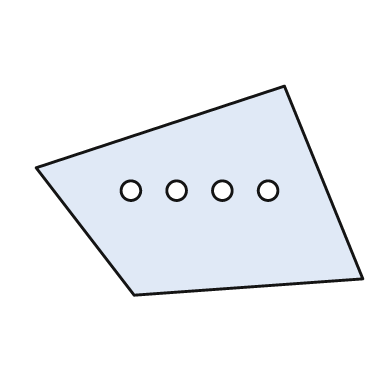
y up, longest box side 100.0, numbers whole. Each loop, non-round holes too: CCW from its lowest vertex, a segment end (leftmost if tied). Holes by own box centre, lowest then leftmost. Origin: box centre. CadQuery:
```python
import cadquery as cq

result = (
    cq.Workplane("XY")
    .moveTo(-20.0, -32.0)
    .lineTo(50.0, -27.0)
    .lineTo(26.0, 32.0)
    .lineTo(-50.0, 7.0)
    .close()
    .moveTo(-21.0, 0.0)
    .circle(3.0)
    .moveTo(-7.0, 0.0)
    .circle(3.0)
    .moveTo(7.0, 0.0)
    .circle(3.0)
    .moveTo(21.0, 0.0)
    .circle(3.0)
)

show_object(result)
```